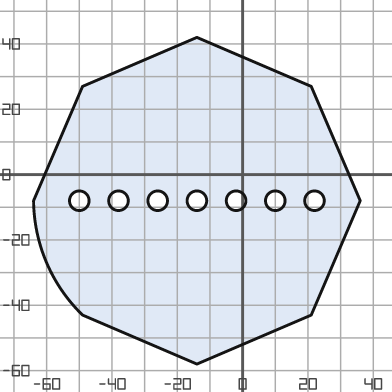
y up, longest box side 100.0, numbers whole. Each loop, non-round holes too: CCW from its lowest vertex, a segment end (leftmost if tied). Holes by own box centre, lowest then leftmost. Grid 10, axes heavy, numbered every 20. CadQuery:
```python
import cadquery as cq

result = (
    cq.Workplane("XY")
    .moveTo(-14.0, -58.0)
    .lineTo(21.0, -43.0)
    .lineTo(36.0, -8.0)
    .lineTo(21.0, 27.0)
    .lineTo(-14.0, 42.0)
    .lineTo(-49.0, 27.0)
    .lineTo(-64.0, -8.0)
    .threePointArc((-60.0, -27.0), (-49.0, -43.0))
    .close()
    .moveTo(-50.0, -8.0)
    .circle(3.0)
    .moveTo(-38.0, -8.0)
    .circle(3.0)
    .moveTo(-26.0, -8.0)
    .circle(3.0)
    .moveTo(-14.0, -8.0)
    .circle(3.0)
    .moveTo(-2.0, -8.0)
    .circle(3.0)
    .moveTo(10.0, -8.0)
    .circle(3.0)
    .moveTo(22.0, -8.0)
    .circle(3.0)
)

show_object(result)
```